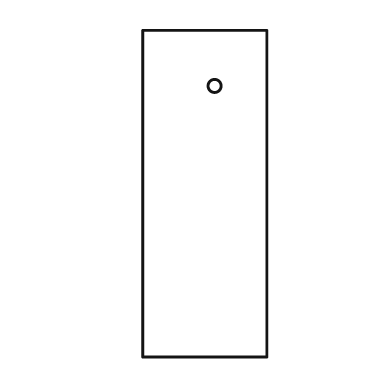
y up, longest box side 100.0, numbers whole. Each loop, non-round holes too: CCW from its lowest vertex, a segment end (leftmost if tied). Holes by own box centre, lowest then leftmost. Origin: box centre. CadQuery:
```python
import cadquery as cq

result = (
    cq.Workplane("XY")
    .moveTo(-19.0, -50.0)
    .lineTo(19.0, -50.0)
    .lineTo(19.0, 50.0)
    .lineTo(-19.0, 50.0)
    .close()
    .moveTo(3.0, 33.0)
    .circle(2.0)
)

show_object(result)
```